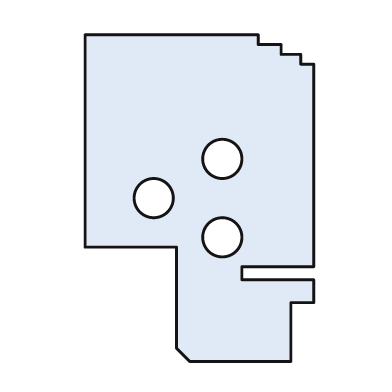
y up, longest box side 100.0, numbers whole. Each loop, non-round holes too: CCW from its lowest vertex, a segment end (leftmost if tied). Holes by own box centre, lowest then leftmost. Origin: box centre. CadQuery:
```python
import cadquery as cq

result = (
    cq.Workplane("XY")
    .moveTo(-3.0, -50.0)
    .lineTo(28.0, -50.0)
    .lineTo(28.0, -32.0)
    .lineTo(35.0, -32.0)
    .lineTo(35.0, -25.0)
    .lineTo(13.0, -25.0)
    .lineTo(13.0, -21.0)
    .lineTo(35.0, -21.0)
    .lineTo(35.0, 41.0)
    .lineTo(31.0, 41.0)
    .lineTo(31.0, 44.0)
    .lineTo(25.0, 44.0)
    .lineTo(25.0, 47.0)
    .lineTo(18.0, 47.0)
    .lineTo(18.0, 50.0)
    .lineTo(-35.0, 50.0)
    .lineTo(-35.0, -15.0)
    .lineTo(-7.0, -15.0)
    .lineTo(-7.0, -46.0)
    .close()
    .moveTo(7.0, -12.0)
    .circle(6.0)
    .moveTo(-14.0, 0.0)
    .circle(6.0)
    .moveTo(7.0, 12.0)
    .circle(6.0)
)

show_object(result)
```